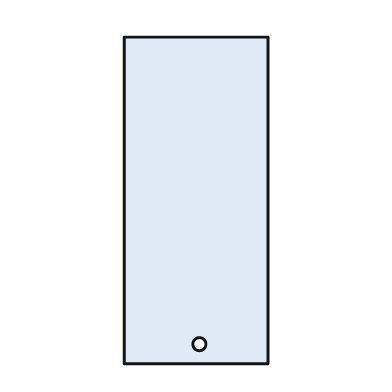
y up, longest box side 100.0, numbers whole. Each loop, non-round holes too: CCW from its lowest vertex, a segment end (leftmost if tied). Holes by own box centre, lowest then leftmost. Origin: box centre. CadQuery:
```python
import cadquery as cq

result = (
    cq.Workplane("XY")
    .moveTo(-22.0, -50.0)
    .lineTo(22.0, -50.0)
    .lineTo(22.0, 50.0)
    .lineTo(-22.0, 50.0)
    .close()
    .moveTo(1.0, -44.0)
    .circle(2.0)
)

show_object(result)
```